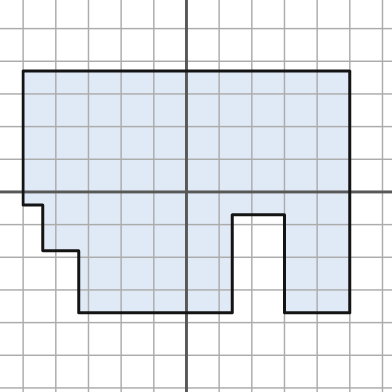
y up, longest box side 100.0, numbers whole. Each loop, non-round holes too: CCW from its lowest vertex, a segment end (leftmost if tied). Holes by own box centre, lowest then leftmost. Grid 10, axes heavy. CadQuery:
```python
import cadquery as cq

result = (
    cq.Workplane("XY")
    .moveTo(-33.0, -37.0)
    .lineTo(14.0, -37.0)
    .lineTo(14.0, -7.0)
    .lineTo(30.0, -7.0)
    .lineTo(30.0, -37.0)
    .lineTo(50.0, -37.0)
    .lineTo(50.0, 37.0)
    .lineTo(-50.0, 37.0)
    .lineTo(-50.0, -4.0)
    .lineTo(-44.0, -4.0)
    .lineTo(-44.0, -18.0)
    .lineTo(-33.0, -18.0)
    .close()
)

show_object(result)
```